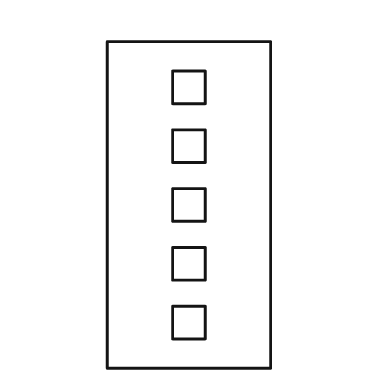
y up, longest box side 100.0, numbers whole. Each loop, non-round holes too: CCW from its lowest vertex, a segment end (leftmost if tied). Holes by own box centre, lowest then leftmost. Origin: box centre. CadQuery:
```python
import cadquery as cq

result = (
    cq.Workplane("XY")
    .moveTo(-25.0, -50.0)
    .lineTo(25.0, -50.0)
    .lineTo(25.0, 50.0)
    .lineTo(-25.0, 50.0)
    .close()
    .moveTo(-5.0, -41.0)
    .lineTo(5.0, -41.0)
    .lineTo(5.0, -31.0)
    .lineTo(-5.0, -31.0)
    .close()
    .moveTo(-5.0, -23.0)
    .lineTo(5.0, -23.0)
    .lineTo(5.0, -13.0)
    .lineTo(-5.0, -13.0)
    .close()
    .moveTo(-5.0, -5.0)
    .lineTo(5.0, -5.0)
    .lineTo(5.0, 5.0)
    .lineTo(-5.0, 5.0)
    .close()
    .moveTo(-5.0, 13.0)
    .lineTo(5.0, 13.0)
    .lineTo(5.0, 23.0)
    .lineTo(-5.0, 23.0)
    .close()
    .moveTo(-5.0, 31.0)
    .lineTo(5.0, 31.0)
    .lineTo(5.0, 41.0)
    .lineTo(-5.0, 41.0)
    .close()
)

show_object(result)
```